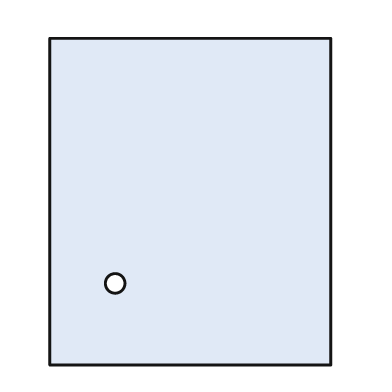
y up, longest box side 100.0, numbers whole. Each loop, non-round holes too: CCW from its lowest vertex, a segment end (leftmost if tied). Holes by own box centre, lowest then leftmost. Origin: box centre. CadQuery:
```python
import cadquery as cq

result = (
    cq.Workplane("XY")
    .moveTo(-43.0, -50.0)
    .lineTo(43.0, -50.0)
    .lineTo(43.0, 50.0)
    .lineTo(-43.0, 50.0)
    .close()
    .moveTo(-23.0, -25.0)
    .circle(3.0)
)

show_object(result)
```